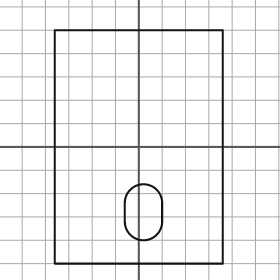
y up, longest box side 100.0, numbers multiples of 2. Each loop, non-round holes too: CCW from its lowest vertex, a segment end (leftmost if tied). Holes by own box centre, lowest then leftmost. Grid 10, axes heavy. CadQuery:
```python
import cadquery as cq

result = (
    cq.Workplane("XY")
    .moveTo(-36.0, -50.0)
    .lineTo(36.0, -50.0)
    .lineTo(36.0, 50.0)
    .lineTo(-36.0, 50.0)
    .close()
    .moveTo(-6.0, -32.0)
    .threePointArc((2.0, -40.0), (10.0, -32.0))
    .lineTo(10.0, -24.0)
    .threePointArc((2.0, -16.0), (-6.0, -24.0))
    .close()
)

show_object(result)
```